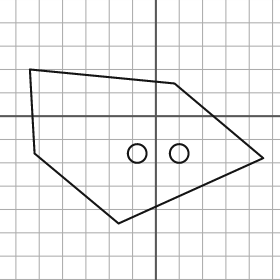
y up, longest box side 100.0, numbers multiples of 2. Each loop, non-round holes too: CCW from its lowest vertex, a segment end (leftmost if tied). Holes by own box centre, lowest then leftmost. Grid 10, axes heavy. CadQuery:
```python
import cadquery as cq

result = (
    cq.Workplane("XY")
    .moveTo(-16.0, -46.0)
    .lineTo(46.0, -18.0)
    .lineTo(8.0, 14.0)
    .lineTo(-54.0, 20.0)
    .lineTo(-52.0, -16.0)
    .close()
    .moveTo(-8.0, -16.0)
    .circle(4.0)
    .moveTo(10.0, -16.0)
    .circle(4.0)
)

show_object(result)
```